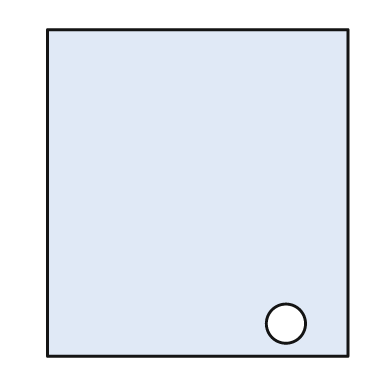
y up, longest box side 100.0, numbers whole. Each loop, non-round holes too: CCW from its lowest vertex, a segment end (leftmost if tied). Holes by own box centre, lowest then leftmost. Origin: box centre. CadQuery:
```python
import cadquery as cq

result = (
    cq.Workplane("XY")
    .moveTo(-46.0, -50.0)
    .lineTo(46.0, -50.0)
    .lineTo(46.0, 50.0)
    .lineTo(-46.0, 50.0)
    .close()
    .moveTo(27.0, -40.0)
    .circle(6.0)
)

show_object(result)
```